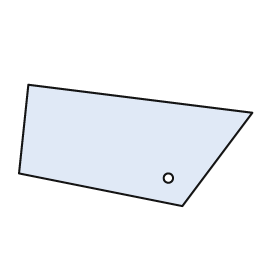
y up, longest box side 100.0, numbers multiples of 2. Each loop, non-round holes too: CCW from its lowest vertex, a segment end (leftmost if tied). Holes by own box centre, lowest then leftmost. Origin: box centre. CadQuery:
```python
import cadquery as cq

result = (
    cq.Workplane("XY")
    .moveTo(20.0, -26.0)
    .lineTo(50.0, 14.0)
    .lineTo(-46.0, 26.0)
    .lineTo(-50.0, -12.0)
    .close()
    .moveTo(14.0, -14.0)
    .circle(2.0)
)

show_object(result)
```